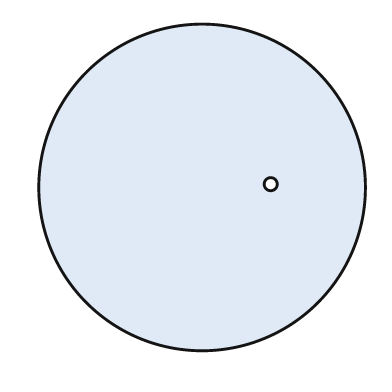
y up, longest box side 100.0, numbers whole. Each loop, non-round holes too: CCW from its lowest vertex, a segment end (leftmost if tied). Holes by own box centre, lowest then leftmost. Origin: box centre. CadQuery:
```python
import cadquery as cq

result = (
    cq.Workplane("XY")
    .moveTo(0.0, 0.0)
    .circle(50.0)
    .moveTo(21.0, 1.0)
    .circle(2.0)
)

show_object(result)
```